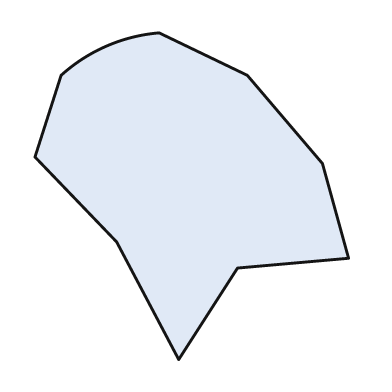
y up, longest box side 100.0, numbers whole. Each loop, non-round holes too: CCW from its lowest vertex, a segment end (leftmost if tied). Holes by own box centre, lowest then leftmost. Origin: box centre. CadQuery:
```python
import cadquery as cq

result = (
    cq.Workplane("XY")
    .moveTo(-4.0, -50.0)
    .lineTo(14.0, -22.0)
    .lineTo(48.0, -19.0)
    .lineTo(40.0, 10.0)
    .lineTo(17.0, 37.0)
    .lineTo(-10.0, 50.0)
    .threePointArc((-26.0, 46.0), (-40.0, 37.0))
    .lineTo(-48.0, 12.0)
    .lineTo(-23.0, -14.0)
    .close()
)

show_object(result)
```